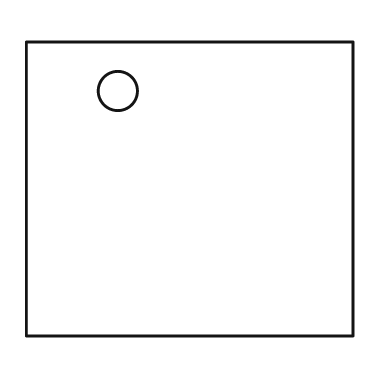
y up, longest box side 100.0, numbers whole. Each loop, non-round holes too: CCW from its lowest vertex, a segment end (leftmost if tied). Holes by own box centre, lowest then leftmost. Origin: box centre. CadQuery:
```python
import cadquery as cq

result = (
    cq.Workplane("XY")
    .moveTo(-50.0, -45.0)
    .lineTo(50.0, -45.0)
    .lineTo(50.0, 45.0)
    .lineTo(-50.0, 45.0)
    .close()
    .moveTo(-22.0, 30.0)
    .circle(6.0)
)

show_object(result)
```